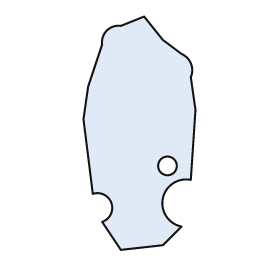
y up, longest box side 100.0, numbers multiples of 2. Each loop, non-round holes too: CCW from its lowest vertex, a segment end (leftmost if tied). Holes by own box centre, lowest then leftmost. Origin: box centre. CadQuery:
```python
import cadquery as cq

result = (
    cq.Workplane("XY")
    .moveTo(-8.0, -50.0)
    .lineTo(10.0, -48.0)
    .lineTo(18.0, -40.0)
    .threePointArc((10.0, -28.0), (22.0, -20.0))
    .lineTo(24.0, 10.0)
    .lineTo(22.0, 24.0)
    .threePointArc((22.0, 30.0), (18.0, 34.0))
    .lineTo(10.0, 40.0)
    .lineTo(2.0, 50.0)
    .lineTo(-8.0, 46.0)
    .threePointArc((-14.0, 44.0), (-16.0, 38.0))
    .lineTo(-22.0, 20.0)
    .lineTo(-24.0, 6.0)
    .lineTo(-20.0, -26.0)
    .threePointArc((-12.0, -30.0), (-16.0, -38.0))
    .close()
    .moveTo(12.0, -14.0)
    .circle(4.0)
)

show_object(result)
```